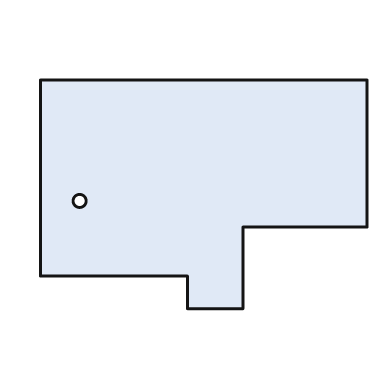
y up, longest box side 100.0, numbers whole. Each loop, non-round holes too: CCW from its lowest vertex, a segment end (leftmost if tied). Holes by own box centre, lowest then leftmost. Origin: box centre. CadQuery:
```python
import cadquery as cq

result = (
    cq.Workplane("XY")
    .moveTo(-5.0, -35.0)
    .lineTo(12.0, -35.0)
    .lineTo(12.0, -10.0)
    .lineTo(50.0, -10.0)
    .lineTo(50.0, 35.0)
    .lineTo(-50.0, 35.0)
    .lineTo(-50.0, -25.0)
    .lineTo(-5.0, -25.0)
    .close()
    .moveTo(-38.0, -2.0)
    .circle(2.0)
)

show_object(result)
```